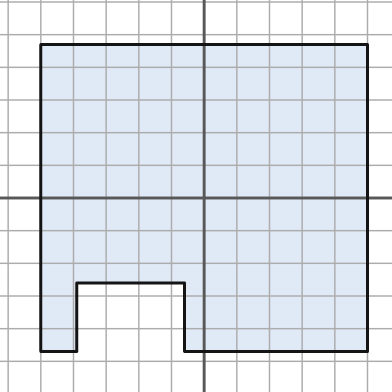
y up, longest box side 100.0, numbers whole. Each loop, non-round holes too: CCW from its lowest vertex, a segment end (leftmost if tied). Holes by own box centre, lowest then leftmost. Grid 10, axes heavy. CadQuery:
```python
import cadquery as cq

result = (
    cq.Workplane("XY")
    .moveTo(-50.0, -47.0)
    .lineTo(-39.0, -47.0)
    .lineTo(-39.0, -26.0)
    .lineTo(-6.0, -26.0)
    .lineTo(-6.0, -47.0)
    .lineTo(50.0, -47.0)
    .lineTo(50.0, 47.0)
    .lineTo(-50.0, 47.0)
    .close()
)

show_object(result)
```